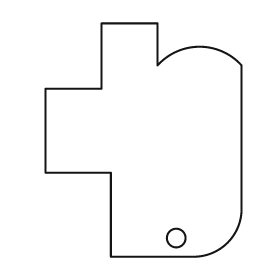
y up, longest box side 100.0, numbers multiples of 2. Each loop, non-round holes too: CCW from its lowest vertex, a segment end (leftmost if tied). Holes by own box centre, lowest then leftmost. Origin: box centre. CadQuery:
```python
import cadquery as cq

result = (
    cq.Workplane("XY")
    .moveTo(-14.0, -50.0)
    .lineTo(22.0, -50.0)
    .threePointArc((36.0, -44.0), (42.0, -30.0))
    .lineTo(42.0, 32.0)
    .threePointArc((24.0, 40.0), (6.0, 32.0))
    .lineTo(6.0, 50.0)
    .lineTo(-18.0, 50.0)
    .lineTo(-18.0, 22.0)
    .lineTo(-42.0, 22.0)
    .lineTo(-42.0, -14.0)
    .lineTo(-14.0, -14.0)
    .close()
    .moveTo(14.0, -42.0)
    .circle(4.0)
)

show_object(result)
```